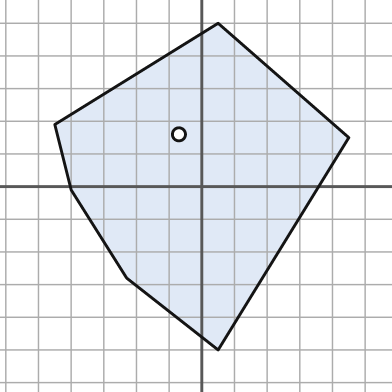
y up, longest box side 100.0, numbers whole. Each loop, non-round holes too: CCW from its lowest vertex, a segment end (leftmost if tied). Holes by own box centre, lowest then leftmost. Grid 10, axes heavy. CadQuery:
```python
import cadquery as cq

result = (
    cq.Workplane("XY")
    .moveTo(5.0, -50.0)
    .lineTo(45.0, 15.0)
    .lineTo(5.0, 50.0)
    .lineTo(-45.0, 19.0)
    .lineTo(-40.0, -1.0)
    .lineTo(-23.0, -28.0)
    .close()
    .moveTo(-7.0, 16.0)
    .circle(2.0)
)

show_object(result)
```